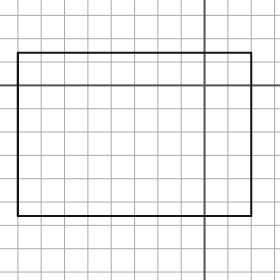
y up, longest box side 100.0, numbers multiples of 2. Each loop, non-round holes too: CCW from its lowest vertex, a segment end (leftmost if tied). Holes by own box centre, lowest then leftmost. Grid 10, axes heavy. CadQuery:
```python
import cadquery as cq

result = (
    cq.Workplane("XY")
    .moveTo(-80.0, -56.0)
    .lineTo(20.0, -56.0)
    .lineTo(20.0, 14.0)
    .lineTo(-80.0, 14.0)
    .close()
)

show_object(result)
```